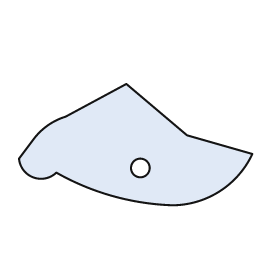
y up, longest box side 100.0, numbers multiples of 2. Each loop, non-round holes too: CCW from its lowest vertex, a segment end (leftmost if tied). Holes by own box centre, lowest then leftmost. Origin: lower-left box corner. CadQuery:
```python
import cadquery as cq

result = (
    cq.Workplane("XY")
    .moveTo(66.0, 0.0)
    .threePointArc((86.0, 6.0), (100.0, 22.0))
    .lineTo(72.0, 30.0)
    .lineTo(46.0, 52.0)
    .lineTo(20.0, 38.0)
    .threePointArc((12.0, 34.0), (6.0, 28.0))
    .lineTo(0.0, 20.0)
    .threePointArc((6.0, 12.0), (16.0, 14.0))
    .threePointArc((40.0, 4.0), (66.0, 0.0))
    .close()
    .moveTo(52.0, 16.0)
    .circle(4.0)
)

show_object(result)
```